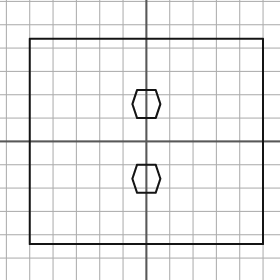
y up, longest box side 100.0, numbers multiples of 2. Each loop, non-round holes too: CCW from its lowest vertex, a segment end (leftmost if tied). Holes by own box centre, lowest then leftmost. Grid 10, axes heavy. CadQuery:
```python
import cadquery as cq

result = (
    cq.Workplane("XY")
    .moveTo(-50.0, -44.0)
    .lineTo(50.0, -44.0)
    .lineTo(50.0, 44.0)
    .lineTo(-50.0, 44.0)
    .close()
    .moveTo(-4.0, -22.0)
    .lineTo(4.0, -22.0)
    .lineTo(6.0, -16.0)
    .lineTo(4.0, -10.0)
    .lineTo(-4.0, -10.0)
    .lineTo(-6.0, -16.0)
    .close()
    .moveTo(-4.0, 10.0)
    .lineTo(4.0, 10.0)
    .lineTo(6.0, 16.0)
    .lineTo(4.0, 22.0)
    .lineTo(-4.0, 22.0)
    .lineTo(-6.0, 16.0)
    .close()
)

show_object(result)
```